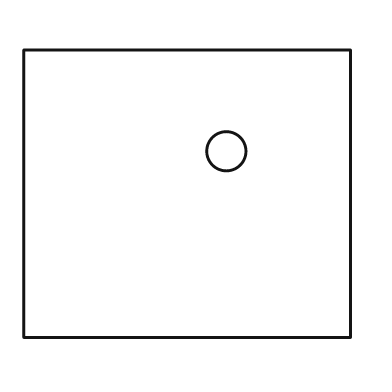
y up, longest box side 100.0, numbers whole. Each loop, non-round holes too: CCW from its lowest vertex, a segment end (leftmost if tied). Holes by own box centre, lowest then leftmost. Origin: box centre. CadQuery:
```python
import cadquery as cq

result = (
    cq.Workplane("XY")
    .moveTo(-50.0, -44.0)
    .lineTo(50.0, -44.0)
    .lineTo(50.0, 44.0)
    .lineTo(-50.0, 44.0)
    .close()
    .moveTo(12.0, 13.0)
    .circle(6.0)
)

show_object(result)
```